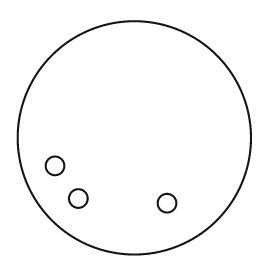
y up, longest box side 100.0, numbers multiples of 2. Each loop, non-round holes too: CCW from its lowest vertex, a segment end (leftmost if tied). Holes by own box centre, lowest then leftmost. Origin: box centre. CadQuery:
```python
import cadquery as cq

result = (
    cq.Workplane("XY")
    .moveTo(0.0, 0.0)
    .circle(50.0)
    .moveTo(14.0, -28.0)
    .circle(4.0)
    .moveTo(-24.0, -26.0)
    .circle(4.0)
    .moveTo(-34.0, -12.0)
    .circle(4.0)
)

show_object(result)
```